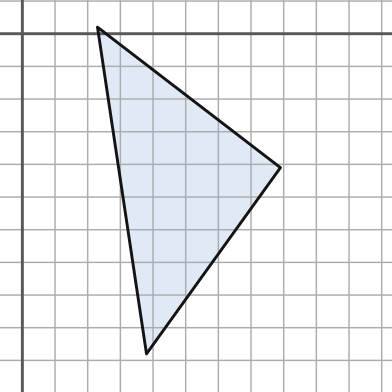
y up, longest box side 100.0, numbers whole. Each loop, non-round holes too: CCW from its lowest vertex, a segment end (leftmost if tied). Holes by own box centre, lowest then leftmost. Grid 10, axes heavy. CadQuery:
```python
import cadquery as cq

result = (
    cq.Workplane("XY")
    .moveTo(38.0, -98.0)
    .lineTo(79.0, -41.0)
    .lineTo(23.0, 2.0)
    .close()
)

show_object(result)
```